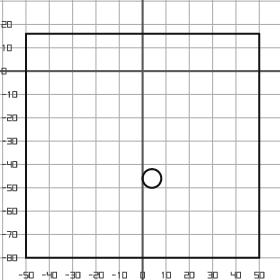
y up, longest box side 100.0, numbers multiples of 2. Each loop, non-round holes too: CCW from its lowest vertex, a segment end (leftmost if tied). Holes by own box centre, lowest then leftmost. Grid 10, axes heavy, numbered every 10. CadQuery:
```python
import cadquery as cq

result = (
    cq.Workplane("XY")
    .moveTo(-50.0, -80.0)
    .lineTo(50.0, -80.0)
    .lineTo(50.0, 16.0)
    .lineTo(-50.0, 16.0)
    .close()
    .moveTo(4.0, -46.0)
    .circle(4.0)
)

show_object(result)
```